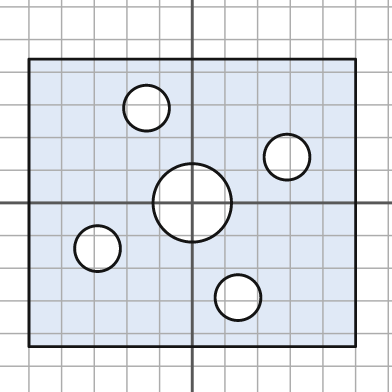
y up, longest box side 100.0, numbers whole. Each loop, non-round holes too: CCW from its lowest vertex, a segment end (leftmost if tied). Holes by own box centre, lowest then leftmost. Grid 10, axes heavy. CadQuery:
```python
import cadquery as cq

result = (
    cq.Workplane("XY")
    .moveTo(-50.0, -44.0)
    .lineTo(50.0, -44.0)
    .lineTo(50.0, 44.0)
    .lineTo(-50.0, 44.0)
    .close()
    .moveTo(14.0, -29.0)
    .circle(7.0)
    .moveTo(-29.0, -14.0)
    .circle(7.0)
    .moveTo(0.0, 0.0)
    .circle(12.0)
    .moveTo(29.0, 14.0)
    .circle(7.0)
    .moveTo(-14.0, 29.0)
    .circle(7.0)
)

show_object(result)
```